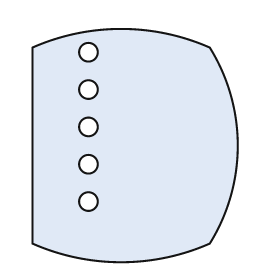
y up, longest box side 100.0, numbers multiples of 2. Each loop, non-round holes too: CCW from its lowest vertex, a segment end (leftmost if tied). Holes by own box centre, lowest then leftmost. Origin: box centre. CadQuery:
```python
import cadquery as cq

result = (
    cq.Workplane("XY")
    .moveTo(-44.0, -42.0)
    .threePointArc((-6.0, -50.0), (32.0, -42.0))
    .threePointArc((44.0, 0.0), (32.0, 42.0))
    .threePointArc((-6.0, 50.0), (-44.0, 42.0))
    .close()
    .moveTo(-20.0, -24.0)
    .circle(4.0)
    .moveTo(-20.0, -8.0)
    .circle(4.0)
    .moveTo(-20.0, 8.0)
    .circle(4.0)
    .moveTo(-20.0, 24.0)
    .circle(4.0)
    .moveTo(-20.0, 40.0)
    .circle(4.0)
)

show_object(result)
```